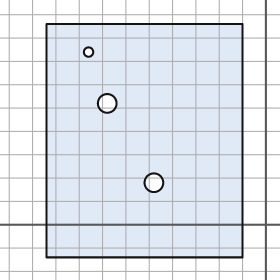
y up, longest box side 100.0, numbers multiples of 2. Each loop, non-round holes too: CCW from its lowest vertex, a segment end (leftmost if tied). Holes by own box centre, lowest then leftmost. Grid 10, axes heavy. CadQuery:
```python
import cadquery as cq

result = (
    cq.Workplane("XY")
    .moveTo(-94.0, -14.0)
    .lineTo(-10.0, -14.0)
    .lineTo(-10.0, 86.0)
    .lineTo(-94.0, 86.0)
    .close()
    .moveTo(-48.0, 18.0)
    .circle(4.0)
    .moveTo(-68.0, 52.0)
    .circle(4.0)
    .moveTo(-76.0, 74.0)
    .circle(2.0)
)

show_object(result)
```